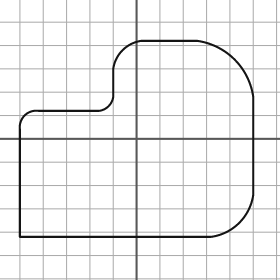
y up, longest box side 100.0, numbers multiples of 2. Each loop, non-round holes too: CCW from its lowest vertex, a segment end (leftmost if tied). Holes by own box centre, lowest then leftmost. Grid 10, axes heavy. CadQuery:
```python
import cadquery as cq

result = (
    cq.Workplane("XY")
    .moveTo(-50.0, -42.0)
    .lineTo(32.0, -42.0)
    .threePointArc((44.0, -36.0), (50.0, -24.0))
    .lineTo(50.0, 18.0)
    .threePointArc((42.0, 34.0), (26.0, 42.0))
    .lineTo(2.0, 42.0)
    .threePointArc((-6.0, 38.0), (-10.0, 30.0))
    .lineTo(-10.0, 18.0)
    .threePointArc((-12.0, 14.0), (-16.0, 12.0))
    .lineTo(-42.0, 12.0)
    .threePointArc((-48.0, 10.0), (-50.0, 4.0))
    .close()
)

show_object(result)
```